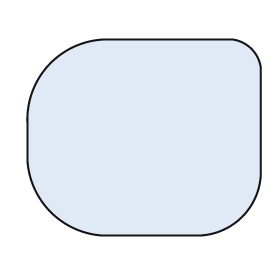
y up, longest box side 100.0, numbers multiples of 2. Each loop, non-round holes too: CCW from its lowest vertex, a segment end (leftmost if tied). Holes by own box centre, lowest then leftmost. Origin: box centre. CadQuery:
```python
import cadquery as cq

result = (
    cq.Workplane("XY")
    .moveTo(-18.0, -42.0)
    .lineTo(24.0, -42.0)
    .threePointArc((42.0, -34.0), (50.0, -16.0))
    .lineTo(50.0, 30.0)
    .threePointArc((46.0, 38.0), (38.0, 42.0))
    .lineTo(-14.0, 42.0)
    .threePointArc((-40.0, 32.0), (-50.0, 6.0))
    .lineTo(-50.0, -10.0)
    .threePointArc((-40.0, -32.0), (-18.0, -42.0))
    .close()
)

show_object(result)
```